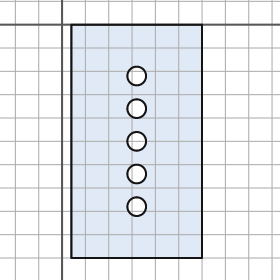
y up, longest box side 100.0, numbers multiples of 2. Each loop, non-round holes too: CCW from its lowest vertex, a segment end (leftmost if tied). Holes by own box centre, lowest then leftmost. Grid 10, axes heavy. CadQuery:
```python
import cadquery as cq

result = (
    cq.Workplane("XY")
    .moveTo(4.0, -100.0)
    .lineTo(60.0, -100.0)
    .lineTo(60.0, 0.0)
    .lineTo(4.0, 0.0)
    .close()
    .moveTo(32.0, -78.0)
    .circle(4.0)
    .moveTo(32.0, -64.0)
    .circle(4.0)
    .moveTo(32.0, -50.0)
    .circle(4.0)
    .moveTo(32.0, -36.0)
    .circle(4.0)
    .moveTo(32.0, -22.0)
    .circle(4.0)
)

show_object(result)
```